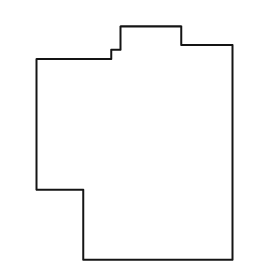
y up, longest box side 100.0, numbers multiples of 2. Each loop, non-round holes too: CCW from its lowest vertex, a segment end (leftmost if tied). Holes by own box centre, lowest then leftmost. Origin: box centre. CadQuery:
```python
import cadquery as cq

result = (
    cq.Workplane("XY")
    .moveTo(-22.0, -50.0)
    .lineTo(42.0, -50.0)
    .lineTo(42.0, 42.0)
    .lineTo(20.0, 42.0)
    .lineTo(20.0, 50.0)
    .lineTo(-6.0, 50.0)
    .lineTo(-6.0, 40.0)
    .lineTo(-10.0, 40.0)
    .lineTo(-10.0, 36.0)
    .lineTo(-42.0, 36.0)
    .lineTo(-42.0, -20.0)
    .lineTo(-22.0, -20.0)
    .close()
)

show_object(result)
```